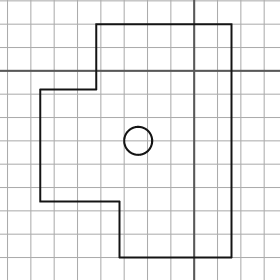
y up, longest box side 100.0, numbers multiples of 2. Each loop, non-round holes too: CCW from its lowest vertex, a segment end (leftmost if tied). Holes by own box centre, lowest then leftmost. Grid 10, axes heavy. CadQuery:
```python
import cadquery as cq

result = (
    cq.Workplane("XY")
    .moveTo(-32.0, -80.0)
    .lineTo(16.0, -80.0)
    .lineTo(16.0, 20.0)
    .lineTo(-42.0, 20.0)
    .lineTo(-42.0, -8.0)
    .lineTo(-66.0, -8.0)
    .lineTo(-66.0, -56.0)
    .lineTo(-32.0, -56.0)
    .close()
    .moveTo(-24.0, -30.0)
    .circle(6.0)
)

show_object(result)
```